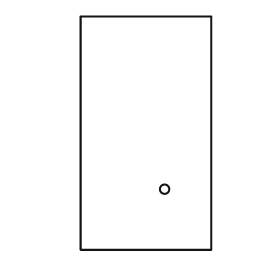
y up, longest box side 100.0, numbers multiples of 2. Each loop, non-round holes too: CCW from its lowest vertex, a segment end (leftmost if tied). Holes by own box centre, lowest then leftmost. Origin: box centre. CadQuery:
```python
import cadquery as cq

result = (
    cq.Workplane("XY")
    .moveTo(-28.0, -50.0)
    .lineTo(28.0, -50.0)
    .lineTo(28.0, 50.0)
    .lineTo(-28.0, 50.0)
    .close()
    .moveTo(8.0, -24.0)
    .circle(2.0)
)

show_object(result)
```